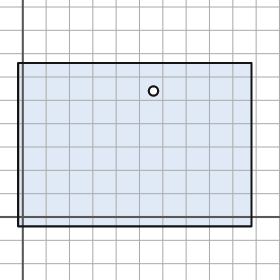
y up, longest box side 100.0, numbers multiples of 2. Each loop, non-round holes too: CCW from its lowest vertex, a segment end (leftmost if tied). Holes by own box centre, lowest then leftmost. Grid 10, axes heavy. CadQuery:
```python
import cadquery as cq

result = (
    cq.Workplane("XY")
    .moveTo(-2.0, -4.0)
    .lineTo(98.0, -4.0)
    .lineTo(98.0, 66.0)
    .lineTo(-2.0, 66.0)
    .close()
    .moveTo(56.0, 54.0)
    .circle(2.0)
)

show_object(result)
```